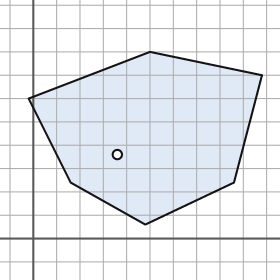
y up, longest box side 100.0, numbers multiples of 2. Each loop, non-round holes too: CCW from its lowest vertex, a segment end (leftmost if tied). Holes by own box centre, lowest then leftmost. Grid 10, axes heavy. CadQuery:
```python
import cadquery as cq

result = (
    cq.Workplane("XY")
    .moveTo(48.0, 6.0)
    .lineTo(86.0, 24.0)
    .lineTo(98.0, 70.0)
    .lineTo(50.0, 80.0)
    .lineTo(-2.0, 60.0)
    .lineTo(16.0, 24.0)
    .close()
    .moveTo(36.0, 36.0)
    .circle(2.0)
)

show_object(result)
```